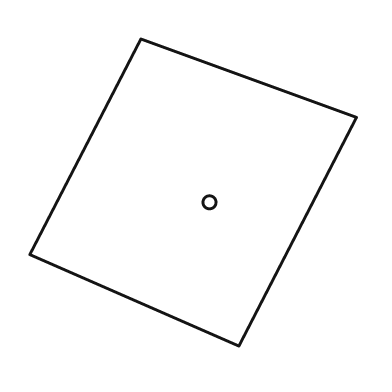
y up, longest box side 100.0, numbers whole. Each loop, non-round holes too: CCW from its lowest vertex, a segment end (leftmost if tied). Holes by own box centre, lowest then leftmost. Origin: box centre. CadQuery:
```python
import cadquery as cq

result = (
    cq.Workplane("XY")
    .moveTo(14.0, -47.0)
    .lineTo(50.0, 23.0)
    .lineTo(-16.0, 47.0)
    .lineTo(-50.0, -19.0)
    .close()
    .moveTo(5.0, -3.0)
    .circle(2.0)
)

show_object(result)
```